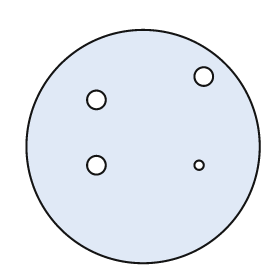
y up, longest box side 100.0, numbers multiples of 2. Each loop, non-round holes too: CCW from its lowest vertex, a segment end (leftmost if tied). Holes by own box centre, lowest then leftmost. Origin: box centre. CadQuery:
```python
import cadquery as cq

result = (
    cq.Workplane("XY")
    .moveTo(0.0, 0.0)
    .circle(50.0)
    .moveTo(-20.0, -8.0)
    .circle(4.0)
    .moveTo(24.0, -8.0)
    .circle(2.0)
    .moveTo(-20.0, 20.0)
    .circle(4.0)
    .moveTo(26.0, 30.0)
    .circle(4.0)
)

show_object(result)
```